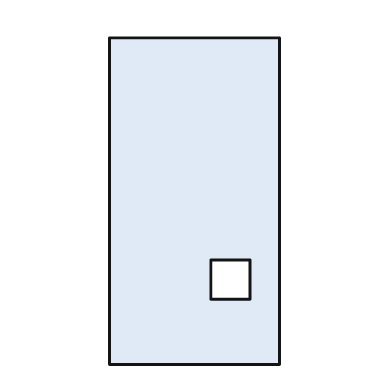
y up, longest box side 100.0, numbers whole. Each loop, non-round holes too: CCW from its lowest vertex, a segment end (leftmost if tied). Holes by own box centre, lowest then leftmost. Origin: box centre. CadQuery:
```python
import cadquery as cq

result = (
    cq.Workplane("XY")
    .moveTo(-26.0, -50.0)
    .lineTo(26.0, -50.0)
    .lineTo(26.0, 50.0)
    .lineTo(-26.0, 50.0)
    .close()
    .moveTo(5.0, -30.0)
    .lineTo(17.0, -30.0)
    .lineTo(17.0, -18.0)
    .lineTo(5.0, -18.0)
    .close()
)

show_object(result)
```